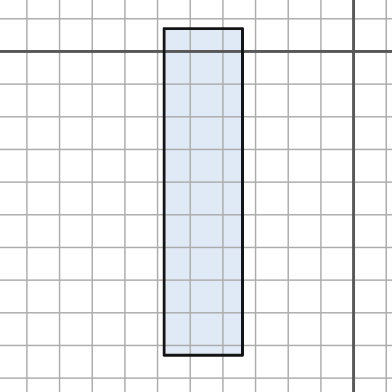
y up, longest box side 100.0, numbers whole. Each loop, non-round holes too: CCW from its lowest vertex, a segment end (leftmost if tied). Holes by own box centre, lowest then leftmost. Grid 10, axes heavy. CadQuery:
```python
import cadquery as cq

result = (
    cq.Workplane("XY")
    .moveTo(-58.0, -93.0)
    .lineTo(-34.0, -93.0)
    .lineTo(-34.0, 7.0)
    .lineTo(-58.0, 7.0)
    .close()
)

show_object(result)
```